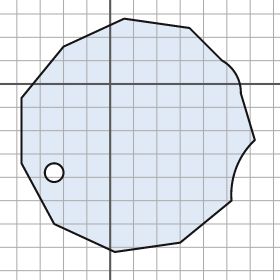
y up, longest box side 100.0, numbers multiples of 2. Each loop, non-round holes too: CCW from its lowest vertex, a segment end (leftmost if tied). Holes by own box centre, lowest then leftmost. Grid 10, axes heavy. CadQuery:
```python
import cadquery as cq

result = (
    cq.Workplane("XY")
    .moveTo(2.0, -72.0)
    .lineTo(30.0, -68.0)
    .lineTo(52.0, -50.0)
    .threePointArc((54.0, -36.0), (62.0, -24.0))
    .lineTo(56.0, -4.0)
    .threePointArc((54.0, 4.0), (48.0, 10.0))
    .lineTo(34.0, 24.0)
    .lineTo(6.0, 28.0)
    .lineTo(-20.0, 16.0)
    .lineTo(-38.0, -6.0)
    .lineTo(-38.0, -34.0)
    .lineTo(-24.0, -60.0)
    .close()
    .moveTo(-24.0, -38.0)
    .circle(4.0)
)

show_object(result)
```